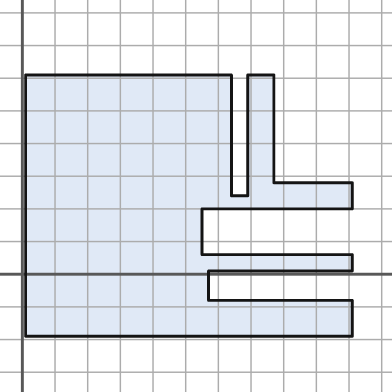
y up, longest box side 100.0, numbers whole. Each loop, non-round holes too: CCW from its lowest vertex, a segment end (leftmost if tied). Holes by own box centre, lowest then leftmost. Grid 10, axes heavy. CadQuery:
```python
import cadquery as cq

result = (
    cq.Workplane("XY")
    .moveTo(1.0, -19.0)
    .lineTo(101.0, -19.0)
    .lineTo(101.0, -8.0)
    .lineTo(57.0, -8.0)
    .lineTo(57.0, 1.0)
    .lineTo(101.0, 1.0)
    .lineTo(101.0, 6.0)
    .lineTo(55.0, 6.0)
    .lineTo(55.0, 20.0)
    .lineTo(101.0, 20.0)
    .lineTo(101.0, 28.0)
    .lineTo(77.0, 28.0)
    .lineTo(77.0, 61.0)
    .lineTo(69.0, 61.0)
    .lineTo(69.0, 24.0)
    .lineTo(64.0, 24.0)
    .lineTo(64.0, 61.0)
    .lineTo(1.0, 61.0)
    .close()
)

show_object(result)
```